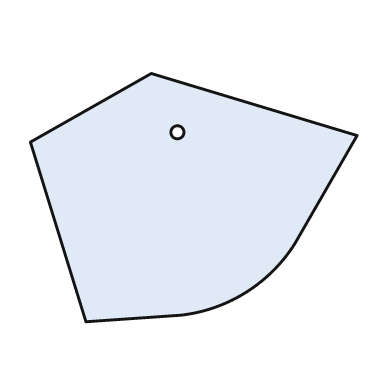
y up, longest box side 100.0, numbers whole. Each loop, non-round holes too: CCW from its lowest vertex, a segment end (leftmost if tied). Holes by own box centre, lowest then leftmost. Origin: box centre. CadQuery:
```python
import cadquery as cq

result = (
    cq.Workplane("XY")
    .moveTo(-33.0, -38.0)
    .lineTo(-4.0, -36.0)
    .threePointArc((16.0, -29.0), (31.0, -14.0))
    .lineTo(50.0, 19.0)
    .lineTo(-13.0, 38.0)
    .lineTo(-50.0, 17.0)
    .close()
    .moveTo(-5.0, 20.0)
    .circle(2.0)
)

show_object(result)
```